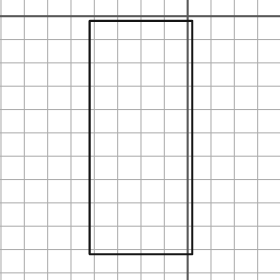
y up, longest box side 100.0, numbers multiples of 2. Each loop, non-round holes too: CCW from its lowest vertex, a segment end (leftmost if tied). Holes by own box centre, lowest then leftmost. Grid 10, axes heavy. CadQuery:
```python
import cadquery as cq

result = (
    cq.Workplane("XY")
    .moveTo(-42.0, -102.0)
    .lineTo(2.0, -102.0)
    .lineTo(2.0, -2.0)
    .lineTo(-42.0, -2.0)
    .close()
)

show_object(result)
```